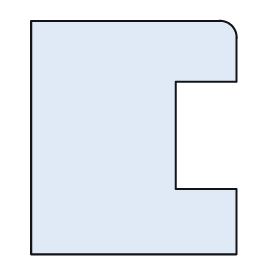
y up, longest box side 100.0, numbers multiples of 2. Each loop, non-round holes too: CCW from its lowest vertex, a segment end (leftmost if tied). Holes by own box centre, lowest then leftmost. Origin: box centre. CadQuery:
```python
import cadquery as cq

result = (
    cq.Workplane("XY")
    .moveTo(-44.0, -50.0)
    .lineTo(44.0, -50.0)
    .lineTo(44.0, -22.0)
    .lineTo(18.0, -22.0)
    .lineTo(18.0, 24.0)
    .lineTo(44.0, 24.0)
    .lineTo(44.0, 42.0)
    .threePointArc((42.0, 48.0), (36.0, 50.0))
    .lineTo(-44.0, 50.0)
    .close()
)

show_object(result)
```